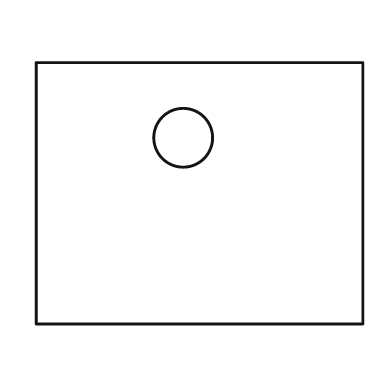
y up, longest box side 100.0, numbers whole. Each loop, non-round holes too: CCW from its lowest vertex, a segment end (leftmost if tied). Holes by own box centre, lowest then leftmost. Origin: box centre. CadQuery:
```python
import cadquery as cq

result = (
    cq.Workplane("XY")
    .moveTo(-50.0, -40.0)
    .lineTo(50.0, -40.0)
    .lineTo(50.0, 40.0)
    .lineTo(-50.0, 40.0)
    .close()
    .moveTo(-5.0, 17.0)
    .circle(9.0)
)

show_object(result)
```